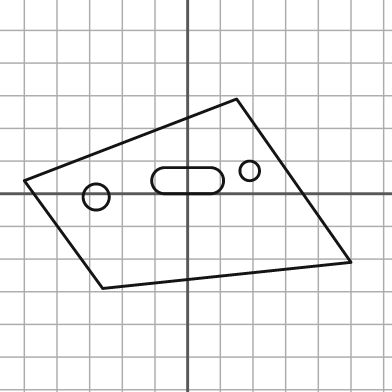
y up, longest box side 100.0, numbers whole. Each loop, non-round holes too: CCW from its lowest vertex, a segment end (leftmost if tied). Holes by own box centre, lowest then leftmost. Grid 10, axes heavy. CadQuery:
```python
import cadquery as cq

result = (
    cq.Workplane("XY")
    .moveTo(-26.0, -29.0)
    .lineTo(50.0, -21.0)
    .lineTo(15.0, 29.0)
    .lineTo(-50.0, 4.0)
    .close()
    .moveTo(-28.0, -1.0)
    .circle(4.0)
    .moveTo(-7.0, 0.0)
    .lineTo(7.0, 0.0)
    .threePointArc((11.0, 4.0), (7.0, 8.0))
    .lineTo(-7.0, 8.0)
    .threePointArc((-11.0, 4.0), (-7.0, 0.0))
    .close()
    .moveTo(19.0, 7.0)
    .circle(3.0)
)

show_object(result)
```